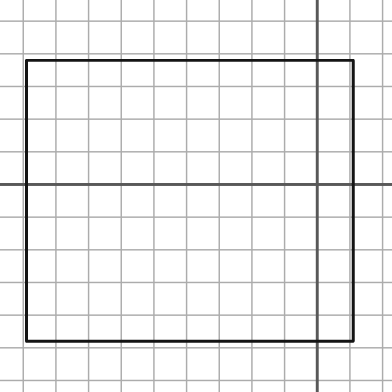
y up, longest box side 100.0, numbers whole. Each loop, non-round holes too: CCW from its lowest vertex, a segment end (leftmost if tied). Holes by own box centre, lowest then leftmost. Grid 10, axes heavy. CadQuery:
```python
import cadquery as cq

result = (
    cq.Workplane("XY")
    .moveTo(-89.0, -48.0)
    .lineTo(11.0, -48.0)
    .lineTo(11.0, 38.0)
    .lineTo(-89.0, 38.0)
    .close()
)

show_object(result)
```